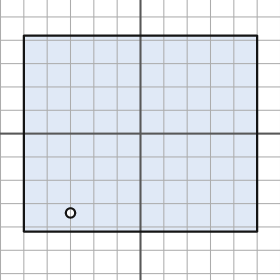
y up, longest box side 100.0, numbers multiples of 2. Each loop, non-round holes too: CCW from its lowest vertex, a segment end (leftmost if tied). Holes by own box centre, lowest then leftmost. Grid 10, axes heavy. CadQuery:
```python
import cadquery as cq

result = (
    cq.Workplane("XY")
    .moveTo(-50.0, -42.0)
    .lineTo(50.0, -42.0)
    .lineTo(50.0, 42.0)
    .lineTo(-50.0, 42.0)
    .close()
    .moveTo(-30.0, -34.0)
    .circle(2.0)
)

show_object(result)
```